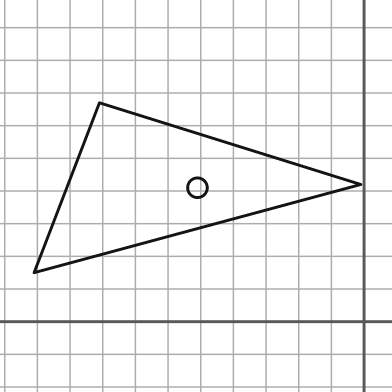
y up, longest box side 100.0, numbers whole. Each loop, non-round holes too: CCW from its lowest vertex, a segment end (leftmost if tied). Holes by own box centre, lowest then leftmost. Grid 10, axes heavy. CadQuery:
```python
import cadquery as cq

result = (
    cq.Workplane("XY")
    .moveTo(-101.0, 15.0)
    .lineTo(-1.0, 42.0)
    .lineTo(-81.0, 67.0)
    .close()
    .moveTo(-51.0, 41.0)
    .circle(3.0)
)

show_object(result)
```